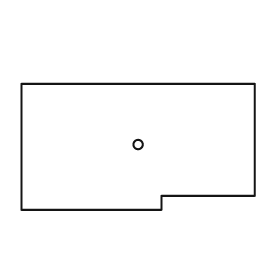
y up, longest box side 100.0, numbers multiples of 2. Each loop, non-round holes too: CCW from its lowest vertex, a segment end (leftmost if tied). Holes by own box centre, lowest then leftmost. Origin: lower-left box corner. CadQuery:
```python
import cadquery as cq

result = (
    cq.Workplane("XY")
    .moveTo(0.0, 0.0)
    .lineTo(60.0, 0.0)
    .lineTo(60.0, 6.0)
    .lineTo(100.0, 6.0)
    .lineTo(100.0, 54.0)
    .lineTo(0.0, 54.0)
    .close()
    .moveTo(50.0, 28.0)
    .circle(2.0)
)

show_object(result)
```